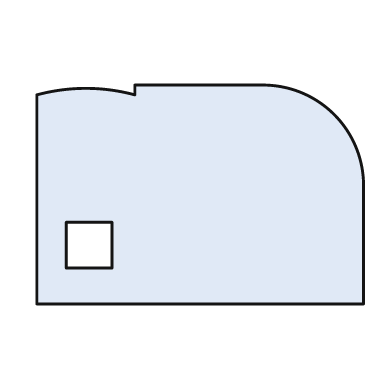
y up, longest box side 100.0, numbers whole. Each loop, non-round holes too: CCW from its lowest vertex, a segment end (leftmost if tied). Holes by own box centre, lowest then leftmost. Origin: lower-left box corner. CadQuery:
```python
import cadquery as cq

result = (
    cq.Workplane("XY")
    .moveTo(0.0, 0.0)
    .lineTo(100.0, 0.0)
    .lineTo(100.0, 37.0)
    .threePointArc((91.0, 58.0), (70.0, 67.0))
    .lineTo(30.0, 67.0)
    .lineTo(30.0, 64.0)
    .threePointArc((15.0, 66.0), (0.0, 64.0))
    .close()
    .moveTo(9.0, 11.0)
    .lineTo(23.0, 11.0)
    .lineTo(23.0, 25.0)
    .lineTo(9.0, 25.0)
    .close()
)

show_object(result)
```